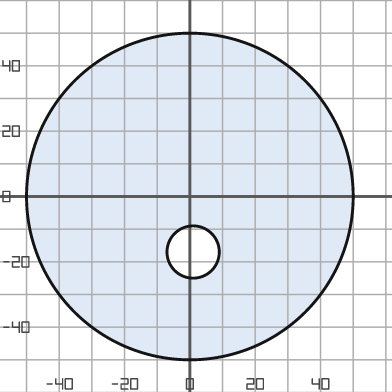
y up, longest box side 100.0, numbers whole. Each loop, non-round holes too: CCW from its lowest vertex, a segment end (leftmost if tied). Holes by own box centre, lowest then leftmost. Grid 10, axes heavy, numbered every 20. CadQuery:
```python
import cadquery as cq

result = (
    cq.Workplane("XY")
    .moveTo(0.0, 0.0)
    .circle(50.0)
    .moveTo(1.0, -17.0)
    .circle(8.0)
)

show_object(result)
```